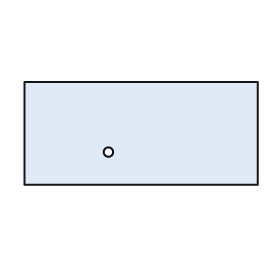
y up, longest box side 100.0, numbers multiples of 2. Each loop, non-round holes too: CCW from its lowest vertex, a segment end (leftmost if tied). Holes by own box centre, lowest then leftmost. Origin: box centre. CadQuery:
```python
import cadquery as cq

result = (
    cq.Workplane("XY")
    .moveTo(-50.0, -22.0)
    .lineTo(50.0, -22.0)
    .lineTo(50.0, 22.0)
    .lineTo(-50.0, 22.0)
    .close()
    .moveTo(-14.0, -8.0)
    .circle(2.0)
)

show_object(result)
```